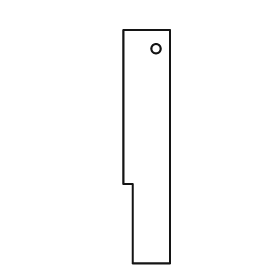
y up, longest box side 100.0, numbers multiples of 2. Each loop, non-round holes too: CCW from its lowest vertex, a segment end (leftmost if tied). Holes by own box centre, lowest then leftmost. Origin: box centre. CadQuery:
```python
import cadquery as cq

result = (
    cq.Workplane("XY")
    .moveTo(-6.0, -50.0)
    .lineTo(10.0, -50.0)
    .lineTo(10.0, 50.0)
    .lineTo(-10.0, 50.0)
    .lineTo(-10.0, -16.0)
    .lineTo(-6.0, -16.0)
    .close()
    .moveTo(4.0, 42.0)
    .circle(2.0)
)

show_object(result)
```